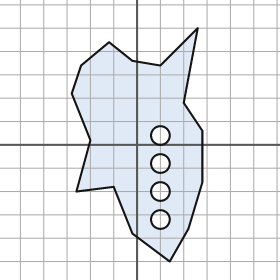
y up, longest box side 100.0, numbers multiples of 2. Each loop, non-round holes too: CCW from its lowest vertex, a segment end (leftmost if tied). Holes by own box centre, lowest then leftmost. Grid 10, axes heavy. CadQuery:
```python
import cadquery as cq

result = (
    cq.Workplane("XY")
    .moveTo(14.0, -50.0)
    .lineTo(22.0, -36.0)
    .lineTo(28.0, -16.0)
    .lineTo(28.0, 6.0)
    .lineTo(20.0, 18.0)
    .lineTo(26.0, 50.0)
    .lineTo(10.0, 34.0)
    .lineTo(-2.0, 36.0)
    .lineTo(-12.0, 44.0)
    .lineTo(-24.0, 34.0)
    .lineTo(-28.0, 22.0)
    .lineTo(-20.0, 2.0)
    .lineTo(-26.0, -20.0)
    .lineTo(-10.0, -18.0)
    .lineTo(-2.0, -38.0)
    .close()
    .moveTo(10.0, -32.0)
    .circle(4.0)
    .moveTo(10.0, -20.0)
    .circle(4.0)
    .moveTo(10.0, -8.0)
    .circle(4.0)
    .moveTo(10.0, 4.0)
    .circle(4.0)
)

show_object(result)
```